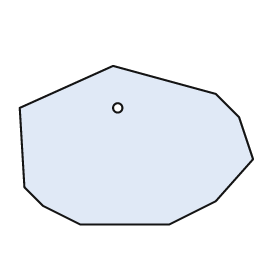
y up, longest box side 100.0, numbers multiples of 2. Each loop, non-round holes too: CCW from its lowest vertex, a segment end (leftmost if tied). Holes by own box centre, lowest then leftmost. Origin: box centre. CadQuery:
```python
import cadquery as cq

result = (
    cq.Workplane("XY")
    .moveTo(-24.0, -34.0)
    .lineTo(14.0, -34.0)
    .lineTo(34.0, -24.0)
    .lineTo(50.0, -6.0)
    .lineTo(44.0, 12.0)
    .lineTo(34.0, 22.0)
    .lineTo(-10.0, 34.0)
    .lineTo(-50.0, 16.0)
    .lineTo(-48.0, -18.0)
    .lineTo(-40.0, -26.0)
    .close()
    .moveTo(-8.0, 16.0)
    .circle(2.0)
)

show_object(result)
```